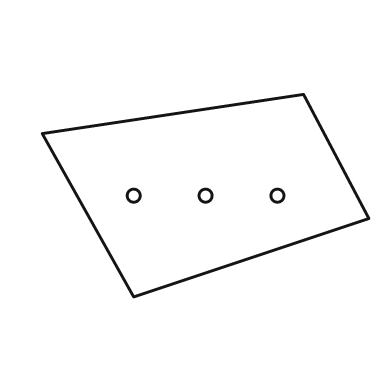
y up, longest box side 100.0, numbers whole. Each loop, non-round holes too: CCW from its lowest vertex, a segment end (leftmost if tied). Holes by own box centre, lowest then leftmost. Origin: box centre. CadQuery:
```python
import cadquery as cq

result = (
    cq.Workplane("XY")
    .moveTo(-22.0, -31.0)
    .lineTo(50.0, -7.0)
    .lineTo(30.0, 31.0)
    .lineTo(-50.0, 19.0)
    .close()
    .moveTo(-22.0, 0.0)
    .circle(2.0)
    .moveTo(0.0, 0.0)
    .circle(2.0)
    .moveTo(22.0, 0.0)
    .circle(2.0)
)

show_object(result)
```